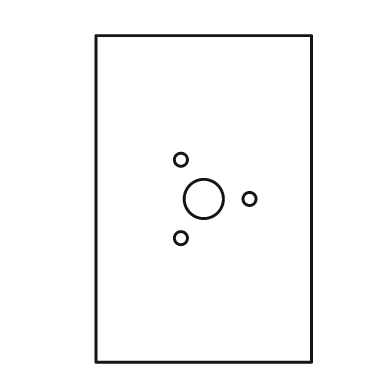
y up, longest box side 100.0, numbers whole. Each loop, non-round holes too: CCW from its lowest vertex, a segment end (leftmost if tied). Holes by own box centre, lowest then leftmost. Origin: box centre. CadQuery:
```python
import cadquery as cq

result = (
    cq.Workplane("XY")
    .moveTo(-33.0, -50.0)
    .lineTo(33.0, -50.0)
    .lineTo(33.0, 50.0)
    .lineTo(-33.0, 50.0)
    .close()
    .moveTo(-7.0, -12.0)
    .circle(2.0)
    .moveTo(0.0, 0.0)
    .circle(6.0)
    .moveTo(14.0, 0.0)
    .circle(2.0)
    .moveTo(-7.0, 12.0)
    .circle(2.0)
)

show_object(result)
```